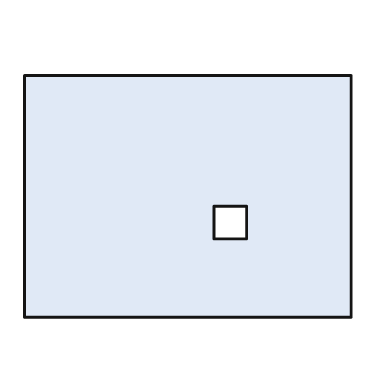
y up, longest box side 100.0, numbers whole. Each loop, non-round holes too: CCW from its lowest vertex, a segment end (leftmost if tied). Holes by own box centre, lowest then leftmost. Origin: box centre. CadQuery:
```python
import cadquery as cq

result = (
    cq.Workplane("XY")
    .moveTo(-50.0, -37.0)
    .lineTo(50.0, -37.0)
    .lineTo(50.0, 37.0)
    .lineTo(-50.0, 37.0)
    .close()
    .moveTo(8.0, -13.0)
    .lineTo(18.0, -13.0)
    .lineTo(18.0, -3.0)
    .lineTo(8.0, -3.0)
    .close()
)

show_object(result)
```